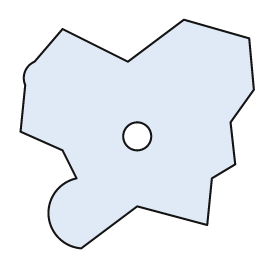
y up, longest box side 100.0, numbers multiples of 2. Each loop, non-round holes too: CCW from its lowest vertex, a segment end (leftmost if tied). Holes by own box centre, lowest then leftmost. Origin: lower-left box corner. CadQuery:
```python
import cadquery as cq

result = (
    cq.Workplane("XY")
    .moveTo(26.0, 0.0)
    .lineTo(50.0, 18.0)
    .lineTo(80.0, 10.0)
    .lineTo(82.0, 30.0)
    .lineTo(92.0, 36.0)
    .lineTo(90.0, 54.0)
    .lineTo(100.0, 68.0)
    .lineTo(98.0, 90.0)
    .lineTo(70.0, 98.0)
    .lineTo(46.0, 80.0)
    .lineTo(18.0, 94.0)
    .lineTo(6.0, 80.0)
    .threePointArc((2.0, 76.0), (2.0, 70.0))
    .lineTo(0.0, 50.0)
    .lineTo(18.0, 42.0)
    .lineTo(24.0, 30.0)
    .threePointArc((12.0, 14.0), (26.0, 0.0))
    .close()
    .moveTo(50.0, 48.0)
    .circle(6.0)
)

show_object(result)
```